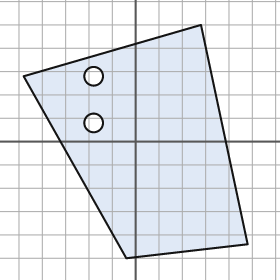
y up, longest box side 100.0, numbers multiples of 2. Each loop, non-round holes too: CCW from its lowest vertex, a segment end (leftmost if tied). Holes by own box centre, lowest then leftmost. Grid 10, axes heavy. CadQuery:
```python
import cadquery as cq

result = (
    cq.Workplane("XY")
    .moveTo(-4.0, -50.0)
    .lineTo(48.0, -44.0)
    .lineTo(28.0, 50.0)
    .lineTo(-48.0, 28.0)
    .close()
    .moveTo(-18.0, 8.0)
    .circle(4.0)
    .moveTo(-18.0, 28.0)
    .circle(4.0)
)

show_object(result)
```